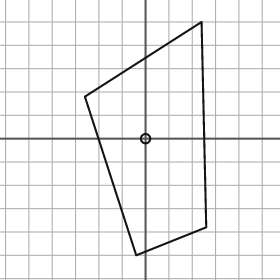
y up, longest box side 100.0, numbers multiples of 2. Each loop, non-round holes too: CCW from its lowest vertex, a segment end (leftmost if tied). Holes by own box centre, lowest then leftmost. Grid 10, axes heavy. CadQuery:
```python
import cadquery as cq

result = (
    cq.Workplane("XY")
    .moveTo(-4.0, -50.0)
    .lineTo(26.0, -38.0)
    .lineTo(24.0, 50.0)
    .lineTo(-26.0, 18.0)
    .close()
    .moveTo(0.0, 0.0)
    .circle(2.0)
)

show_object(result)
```